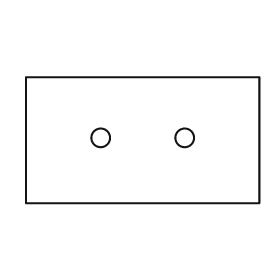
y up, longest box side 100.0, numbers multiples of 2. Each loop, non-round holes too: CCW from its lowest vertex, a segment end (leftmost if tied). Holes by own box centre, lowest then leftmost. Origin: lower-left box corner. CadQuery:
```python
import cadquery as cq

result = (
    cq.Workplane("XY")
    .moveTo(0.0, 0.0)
    .lineTo(100.0, 0.0)
    .lineTo(100.0, 54.0)
    .lineTo(0.0, 54.0)
    .close()
    .moveTo(32.0, 28.0)
    .circle(4.0)
    .moveTo(68.0, 28.0)
    .circle(4.0)
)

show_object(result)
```